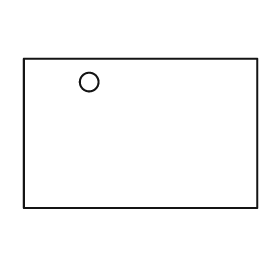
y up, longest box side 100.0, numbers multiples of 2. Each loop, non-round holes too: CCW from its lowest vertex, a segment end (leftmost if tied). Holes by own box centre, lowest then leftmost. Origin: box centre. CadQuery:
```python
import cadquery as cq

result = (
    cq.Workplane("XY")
    .moveTo(-50.0, -32.0)
    .lineTo(50.0, -32.0)
    .lineTo(50.0, 32.0)
    .lineTo(-50.0, 32.0)
    .close()
    .moveTo(-22.0, 22.0)
    .circle(4.0)
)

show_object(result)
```